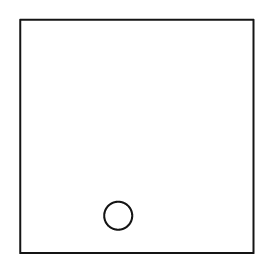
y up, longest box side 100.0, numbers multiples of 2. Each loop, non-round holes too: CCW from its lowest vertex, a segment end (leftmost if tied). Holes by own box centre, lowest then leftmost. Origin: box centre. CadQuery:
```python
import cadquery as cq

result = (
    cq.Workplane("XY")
    .moveTo(-50.0, -50.0)
    .lineTo(50.0, -50.0)
    .lineTo(50.0, 50.0)
    .lineTo(-50.0, 50.0)
    .close()
    .moveTo(-8.0, -34.0)
    .circle(6.0)
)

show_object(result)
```